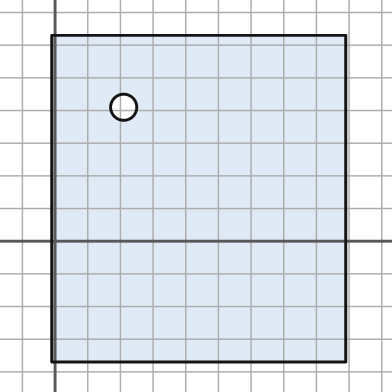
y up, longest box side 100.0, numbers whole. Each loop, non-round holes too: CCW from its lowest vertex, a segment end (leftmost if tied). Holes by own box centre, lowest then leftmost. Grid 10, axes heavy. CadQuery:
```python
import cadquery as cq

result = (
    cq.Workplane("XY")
    .moveTo(-1.0, -37.0)
    .lineTo(89.0, -37.0)
    .lineTo(89.0, 63.0)
    .lineTo(-1.0, 63.0)
    .close()
    .moveTo(21.0, 41.0)
    .circle(4.0)
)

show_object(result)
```